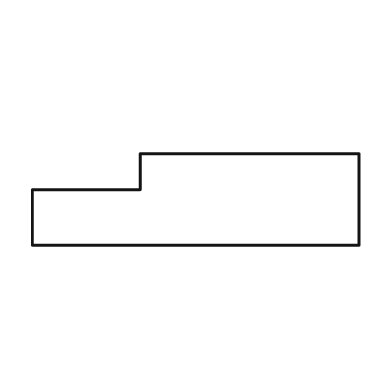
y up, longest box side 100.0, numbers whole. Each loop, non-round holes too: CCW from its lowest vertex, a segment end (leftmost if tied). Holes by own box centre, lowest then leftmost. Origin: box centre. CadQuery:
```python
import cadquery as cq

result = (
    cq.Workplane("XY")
    .moveTo(-50.0, -14.0)
    .lineTo(50.0, -14.0)
    .lineTo(50.0, 14.0)
    .lineTo(-17.0, 14.0)
    .lineTo(-17.0, 3.0)
    .lineTo(-50.0, 3.0)
    .close()
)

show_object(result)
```